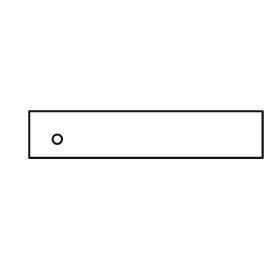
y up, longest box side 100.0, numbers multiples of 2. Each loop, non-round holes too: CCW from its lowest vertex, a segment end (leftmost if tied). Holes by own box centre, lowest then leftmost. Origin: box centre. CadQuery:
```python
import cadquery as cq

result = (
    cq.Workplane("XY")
    .moveTo(-50.0, -10.0)
    .lineTo(50.0, -10.0)
    .lineTo(50.0, 10.0)
    .lineTo(-50.0, 10.0)
    .close()
    .moveTo(-38.0, -2.0)
    .circle(2.0)
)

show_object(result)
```